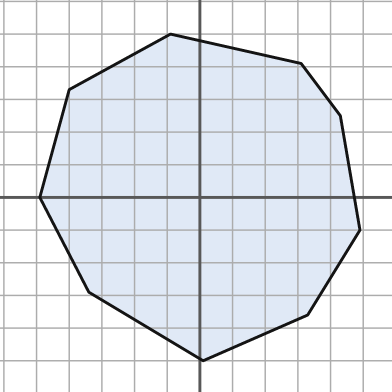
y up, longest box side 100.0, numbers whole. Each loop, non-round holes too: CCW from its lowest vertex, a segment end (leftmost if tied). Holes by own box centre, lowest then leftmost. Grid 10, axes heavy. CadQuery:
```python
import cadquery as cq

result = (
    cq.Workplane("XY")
    .moveTo(1.0, -50.0)
    .lineTo(33.0, -36.0)
    .lineTo(49.0, -10.0)
    .lineTo(43.0, 25.0)
    .lineTo(31.0, 41.0)
    .lineTo(-9.0, 50.0)
    .lineTo(-40.0, 33.0)
    .lineTo(-49.0, 0.0)
    .lineTo(-34.0, -29.0)
    .close()
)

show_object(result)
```